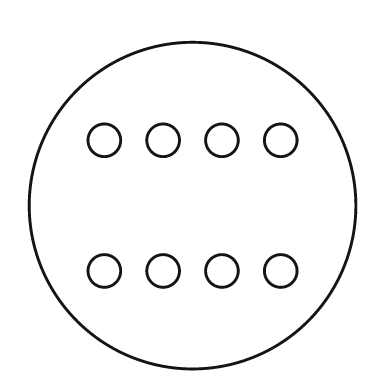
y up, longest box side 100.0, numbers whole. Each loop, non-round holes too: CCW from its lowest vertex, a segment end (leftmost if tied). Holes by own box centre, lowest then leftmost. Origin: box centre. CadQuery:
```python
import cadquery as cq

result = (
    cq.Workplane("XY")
    .moveTo(0.0, 0.0)
    .circle(50.0)
    .moveTo(-27.0, -20.0)
    .circle(5.0)
    .moveTo(-9.0, -20.0)
    .circle(5.0)
    .moveTo(9.0, -20.0)
    .circle(5.0)
    .moveTo(27.0, -20.0)
    .circle(5.0)
    .moveTo(-27.0, 20.0)
    .circle(5.0)
    .moveTo(-9.0, 20.0)
    .circle(5.0)
    .moveTo(9.0, 20.0)
    .circle(5.0)
    .moveTo(27.0, 20.0)
    .circle(5.0)
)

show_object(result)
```